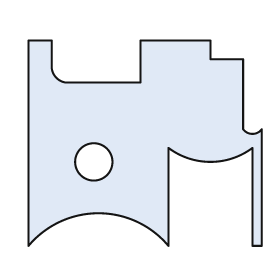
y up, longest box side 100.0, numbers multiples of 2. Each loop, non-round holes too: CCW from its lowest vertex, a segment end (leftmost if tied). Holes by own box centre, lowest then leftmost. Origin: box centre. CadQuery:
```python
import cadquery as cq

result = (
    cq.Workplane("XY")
    .moveTo(-50.0, -44.0)
    .threePointArc((-20.0, -30.0), (10.0, -44.0))
    .lineTo(10.0, -2.0)
    .threePointArc((28.0, -8.0), (46.0, -2.0))
    .lineTo(46.0, -44.0)
    .lineTo(50.0, -44.0)
    .lineTo(50.0, 6.0)
    .threePointArc((46.0, 4.0), (42.0, 6.0))
    .lineTo(42.0, 36.0)
    .lineTo(28.0, 36.0)
    .lineTo(28.0, 44.0)
    .lineTo(-2.0, 44.0)
    .lineTo(-2.0, 26.0)
    .lineTo(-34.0, 26.0)
    .threePointArc((-38.0, 28.0), (-40.0, 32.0))
    .lineTo(-40.0, 44.0)
    .lineTo(-50.0, 44.0)
    .close()
    .moveTo(-22.0, -8.0)
    .circle(8.0)
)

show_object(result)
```